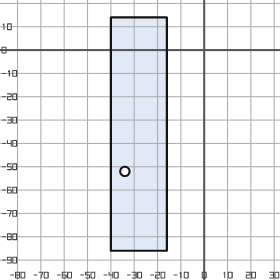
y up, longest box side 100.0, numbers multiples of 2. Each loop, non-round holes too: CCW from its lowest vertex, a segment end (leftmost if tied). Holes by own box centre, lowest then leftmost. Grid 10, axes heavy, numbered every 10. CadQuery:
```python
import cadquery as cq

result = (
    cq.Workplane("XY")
    .moveTo(-40.0, -86.0)
    .lineTo(-16.0, -86.0)
    .lineTo(-16.0, 14.0)
    .lineTo(-40.0, 14.0)
    .close()
    .moveTo(-34.0, -52.0)
    .circle(2.0)
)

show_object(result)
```